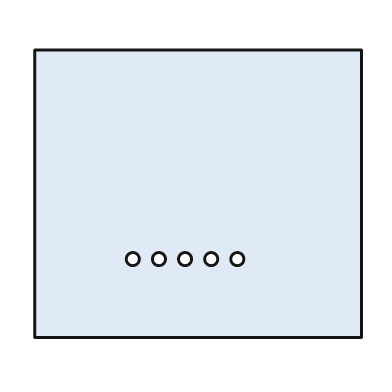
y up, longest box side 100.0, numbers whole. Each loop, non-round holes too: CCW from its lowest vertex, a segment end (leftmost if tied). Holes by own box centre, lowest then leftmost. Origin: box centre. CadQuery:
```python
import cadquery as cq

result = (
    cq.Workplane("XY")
    .moveTo(-50.0, -44.0)
    .lineTo(50.0, -44.0)
    .lineTo(50.0, 44.0)
    .lineTo(-50.0, 44.0)
    .close()
    .moveTo(-20.0, -20.0)
    .circle(2.0)
    .moveTo(-12.0, -20.0)
    .circle(2.0)
    .moveTo(-4.0, -20.0)
    .circle(2.0)
    .moveTo(4.0, -20.0)
    .circle(2.0)
    .moveTo(12.0, -20.0)
    .circle(2.0)
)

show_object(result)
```